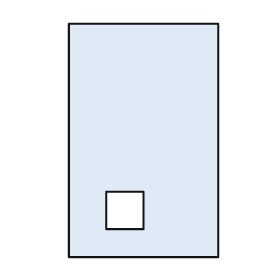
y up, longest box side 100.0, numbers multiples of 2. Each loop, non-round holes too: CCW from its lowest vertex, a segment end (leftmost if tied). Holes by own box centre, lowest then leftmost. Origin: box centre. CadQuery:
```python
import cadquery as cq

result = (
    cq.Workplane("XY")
    .moveTo(-32.0, -50.0)
    .lineTo(32.0, -50.0)
    .lineTo(32.0, 50.0)
    .lineTo(-32.0, 50.0)
    .close()
    .moveTo(-16.0, -38.0)
    .lineTo(0.0, -38.0)
    .lineTo(0.0, -22.0)
    .lineTo(-16.0, -22.0)
    .close()
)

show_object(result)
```